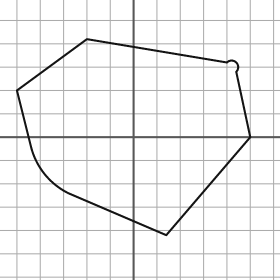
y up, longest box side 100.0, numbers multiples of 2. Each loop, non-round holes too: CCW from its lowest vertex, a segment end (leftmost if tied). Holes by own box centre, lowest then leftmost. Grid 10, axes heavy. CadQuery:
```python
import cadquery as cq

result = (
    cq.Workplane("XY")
    .moveTo(14.0, -42.0)
    .lineTo(50.0, 0.0)
    .lineTo(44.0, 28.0)
    .threePointArc((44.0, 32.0), (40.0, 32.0))
    .lineTo(-20.0, 42.0)
    .lineTo(-50.0, 20.0)
    .lineTo(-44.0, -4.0)
    .threePointArc((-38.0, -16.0), (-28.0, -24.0))
    .close()
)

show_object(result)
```